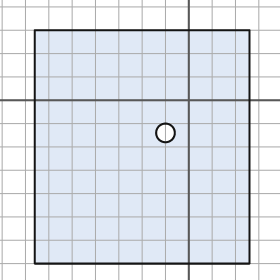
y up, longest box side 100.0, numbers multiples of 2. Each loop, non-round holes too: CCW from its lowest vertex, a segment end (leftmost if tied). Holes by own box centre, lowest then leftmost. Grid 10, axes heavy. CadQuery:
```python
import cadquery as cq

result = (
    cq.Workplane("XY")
    .moveTo(-66.0, -70.0)
    .lineTo(26.0, -70.0)
    .lineTo(26.0, 30.0)
    .lineTo(-66.0, 30.0)
    .close()
    .moveTo(-10.0, -14.0)
    .circle(4.0)
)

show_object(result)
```